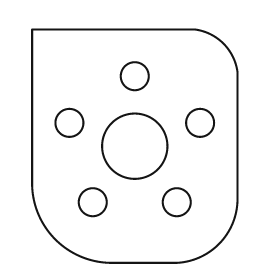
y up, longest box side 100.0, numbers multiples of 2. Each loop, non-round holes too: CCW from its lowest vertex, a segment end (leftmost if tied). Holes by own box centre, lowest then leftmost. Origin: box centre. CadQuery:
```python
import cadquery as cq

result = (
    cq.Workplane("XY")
    .moveTo(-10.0, -50.0)
    .lineTo(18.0, -50.0)
    .threePointArc((36.0, -42.0), (44.0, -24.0))
    .lineTo(44.0, 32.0)
    .threePointArc((38.0, 44.0), (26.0, 50.0))
    .lineTo(-44.0, 50.0)
    .lineTo(-44.0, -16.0)
    .threePointArc((-34.0, -40.0), (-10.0, -50.0))
    .close()
    .moveTo(-18.0, -24.0)
    .circle(6.0)
    .moveTo(18.0, -24.0)
    .circle(6.0)
    .moveTo(0.0, 0.0)
    .circle(14.0)
    .moveTo(-28.0, 10.0)
    .circle(6.0)
    .moveTo(28.0, 10.0)
    .circle(6.0)
    .moveTo(0.0, 30.0)
    .circle(6.0)
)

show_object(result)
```